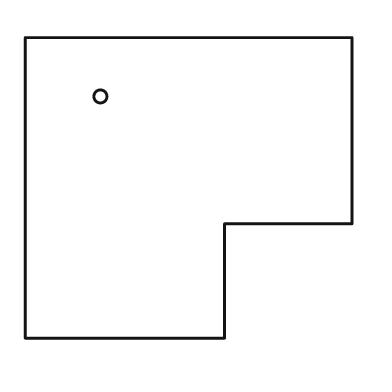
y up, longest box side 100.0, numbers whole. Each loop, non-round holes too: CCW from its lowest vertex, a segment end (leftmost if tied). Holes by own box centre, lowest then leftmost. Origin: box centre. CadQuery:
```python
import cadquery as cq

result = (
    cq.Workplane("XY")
    .moveTo(-50.0, -46.0)
    .lineTo(11.0, -46.0)
    .lineTo(11.0, -11.0)
    .lineTo(50.0, -11.0)
    .lineTo(50.0, 46.0)
    .lineTo(-50.0, 46.0)
    .close()
    .moveTo(-27.0, 28.0)
    .circle(2.0)
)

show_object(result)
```